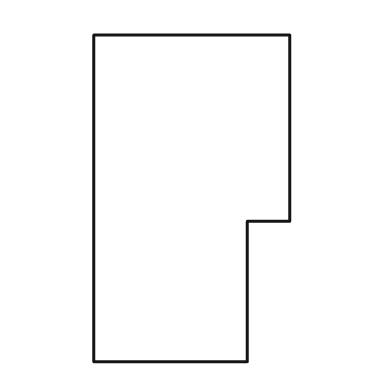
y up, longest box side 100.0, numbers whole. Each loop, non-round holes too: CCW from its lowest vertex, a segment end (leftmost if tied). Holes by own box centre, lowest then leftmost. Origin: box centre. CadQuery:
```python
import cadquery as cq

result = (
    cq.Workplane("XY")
    .moveTo(-30.0, -50.0)
    .lineTo(17.0, -50.0)
    .lineTo(17.0, -7.0)
    .lineTo(30.0, -7.0)
    .lineTo(30.0, 50.0)
    .lineTo(-30.0, 50.0)
    .close()
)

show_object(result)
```